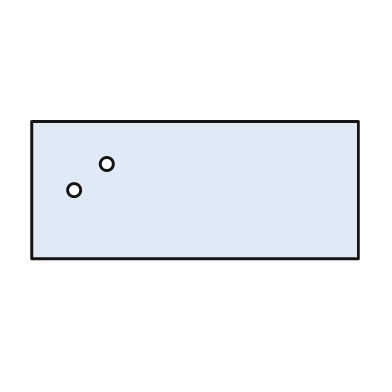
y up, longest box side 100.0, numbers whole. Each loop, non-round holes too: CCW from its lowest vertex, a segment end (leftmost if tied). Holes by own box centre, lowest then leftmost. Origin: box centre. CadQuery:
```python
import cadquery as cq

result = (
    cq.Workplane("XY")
    .moveTo(-50.0, -21.0)
    .lineTo(50.0, -21.0)
    .lineTo(50.0, 21.0)
    .lineTo(-50.0, 21.0)
    .close()
    .moveTo(-37.0, 0.0)
    .circle(2.0)
    .moveTo(-27.0, 8.0)
    .circle(2.0)
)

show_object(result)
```